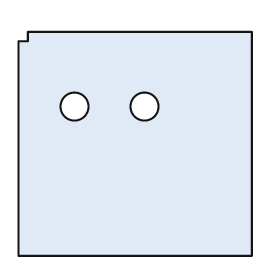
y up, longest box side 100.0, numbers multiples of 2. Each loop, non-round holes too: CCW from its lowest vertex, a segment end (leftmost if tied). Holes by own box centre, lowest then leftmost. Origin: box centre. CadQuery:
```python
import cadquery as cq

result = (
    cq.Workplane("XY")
    .moveTo(-50.0, -48.0)
    .lineTo(50.0, -48.0)
    .lineTo(50.0, 48.0)
    .lineTo(-46.0, 48.0)
    .lineTo(-46.0, 44.0)
    .lineTo(-50.0, 44.0)
    .close()
    .moveTo(-26.0, 16.0)
    .circle(6.0)
    .moveTo(4.0, 16.0)
    .circle(6.0)
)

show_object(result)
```